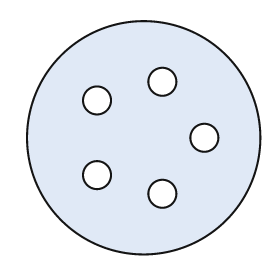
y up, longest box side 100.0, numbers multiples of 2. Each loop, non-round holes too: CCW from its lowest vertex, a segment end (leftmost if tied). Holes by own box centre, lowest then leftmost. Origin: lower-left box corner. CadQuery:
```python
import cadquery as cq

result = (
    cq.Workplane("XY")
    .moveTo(50.0, 50.0)
    .circle(50.0)
    .moveTo(58.0, 26.0)
    .circle(6.0)
    .moveTo(30.0, 34.0)
    .circle(6.0)
    .moveTo(76.0, 50.0)
    .circle(6.0)
    .moveTo(30.0, 66.0)
    .circle(6.0)
    .moveTo(58.0, 74.0)
    .circle(6.0)
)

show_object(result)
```